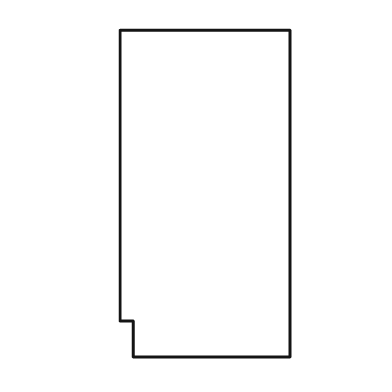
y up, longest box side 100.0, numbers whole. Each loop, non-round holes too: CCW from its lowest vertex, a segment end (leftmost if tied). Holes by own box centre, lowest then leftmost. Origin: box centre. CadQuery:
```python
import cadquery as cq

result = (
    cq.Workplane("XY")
    .moveTo(-22.0, -50.0)
    .lineTo(26.0, -50.0)
    .lineTo(26.0, 50.0)
    .lineTo(-26.0, 50.0)
    .lineTo(-26.0, -39.0)
    .lineTo(-22.0, -39.0)
    .close()
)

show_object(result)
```